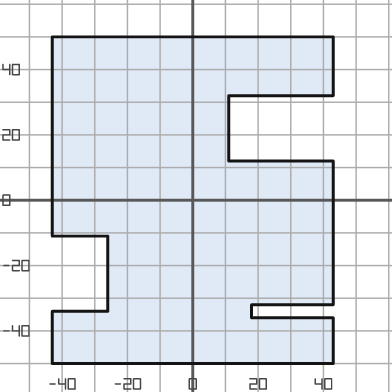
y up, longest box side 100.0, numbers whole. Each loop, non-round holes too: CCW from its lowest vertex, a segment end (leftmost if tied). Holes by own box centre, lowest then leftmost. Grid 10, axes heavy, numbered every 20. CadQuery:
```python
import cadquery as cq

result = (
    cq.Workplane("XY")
    .moveTo(-43.0, -50.0)
    .lineTo(43.0, -50.0)
    .lineTo(43.0, -36.0)
    .lineTo(18.0, -36.0)
    .lineTo(18.0, -32.0)
    .lineTo(43.0, -32.0)
    .lineTo(43.0, 12.0)
    .lineTo(11.0, 12.0)
    .lineTo(11.0, 32.0)
    .lineTo(43.0, 32.0)
    .lineTo(43.0, 50.0)
    .lineTo(-43.0, 50.0)
    .lineTo(-43.0, -11.0)
    .lineTo(-26.0, -11.0)
    .lineTo(-26.0, -34.0)
    .lineTo(-43.0, -34.0)
    .close()
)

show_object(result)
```